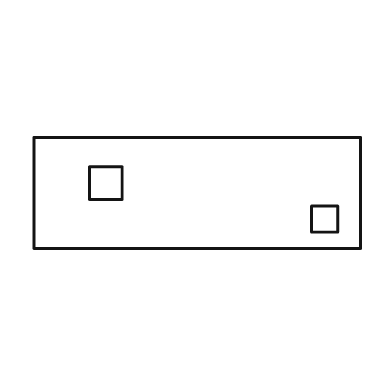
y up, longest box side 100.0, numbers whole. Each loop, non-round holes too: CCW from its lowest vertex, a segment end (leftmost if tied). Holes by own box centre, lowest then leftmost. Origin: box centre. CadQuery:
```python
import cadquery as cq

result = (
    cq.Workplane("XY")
    .moveTo(-50.0, -17.0)
    .lineTo(50.0, -17.0)
    .lineTo(50.0, 17.0)
    .lineTo(-50.0, 17.0)
    .close()
    .moveTo(35.0, -12.0)
    .lineTo(43.0, -12.0)
    .lineTo(43.0, -4.0)
    .lineTo(35.0, -4.0)
    .close()
    .moveTo(-33.0, -2.0)
    .lineTo(-23.0, -2.0)
    .lineTo(-23.0, 8.0)
    .lineTo(-33.0, 8.0)
    .close()
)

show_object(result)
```